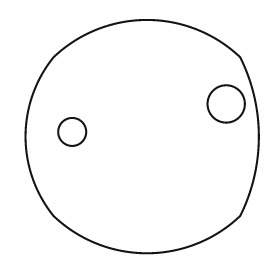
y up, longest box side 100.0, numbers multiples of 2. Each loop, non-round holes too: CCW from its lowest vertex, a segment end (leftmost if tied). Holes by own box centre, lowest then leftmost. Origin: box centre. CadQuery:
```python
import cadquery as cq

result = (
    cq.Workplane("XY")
    .moveTo(-38.0, -34.0)
    .threePointArc((2.0, -50.0), (42.0, -34.0))
    .threePointArc((50.0, 0.0), (42.0, 34.0))
    .threePointArc((2.0, 50.0), (-38.0, 34.0))
    .threePointArc((-50.0, 0.0), (-38.0, -34.0))
    .close()
    .moveTo(-30.0, 2.0)
    .circle(6.0)
    .moveTo(36.0, 14.0)
    .circle(8.0)
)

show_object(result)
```